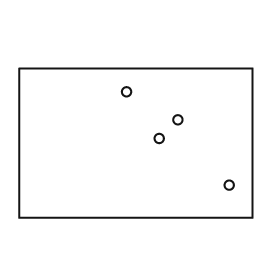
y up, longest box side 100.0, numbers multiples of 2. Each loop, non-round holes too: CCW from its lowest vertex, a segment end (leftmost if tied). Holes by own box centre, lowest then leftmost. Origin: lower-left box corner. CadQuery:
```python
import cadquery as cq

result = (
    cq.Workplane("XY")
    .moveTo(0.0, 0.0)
    .lineTo(100.0, 0.0)
    .lineTo(100.0, 64.0)
    .lineTo(0.0, 64.0)
    .close()
    .moveTo(90.0, 14.0)
    .circle(2.0)
    .moveTo(60.0, 34.0)
    .circle(2.0)
    .moveTo(68.0, 42.0)
    .circle(2.0)
    .moveTo(46.0, 54.0)
    .circle(2.0)
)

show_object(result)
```